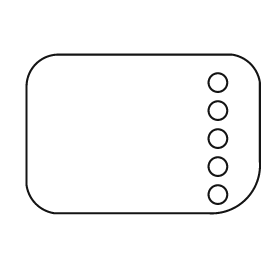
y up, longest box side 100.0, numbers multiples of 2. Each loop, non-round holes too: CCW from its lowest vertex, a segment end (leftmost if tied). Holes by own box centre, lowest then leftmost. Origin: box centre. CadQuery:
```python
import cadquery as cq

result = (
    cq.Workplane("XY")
    .moveTo(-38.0, -34.0)
    .lineTo(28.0, -34.0)
    .threePointArc((44.0, -28.0), (50.0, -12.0))
    .lineTo(50.0, 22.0)
    .threePointArc((46.0, 30.0), (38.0, 34.0))
    .lineTo(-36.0, 34.0)
    .threePointArc((-46.0, 30.0), (-50.0, 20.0))
    .lineTo(-50.0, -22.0)
    .threePointArc((-46.0, -30.0), (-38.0, -34.0))
    .close()
    .moveTo(32.0, -26.0)
    .circle(4.0)
    .moveTo(32.0, -14.0)
    .circle(4.0)
    .moveTo(32.0, -2.0)
    .circle(4.0)
    .moveTo(32.0, 10.0)
    .circle(4.0)
    .moveTo(32.0, 22.0)
    .circle(4.0)
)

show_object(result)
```